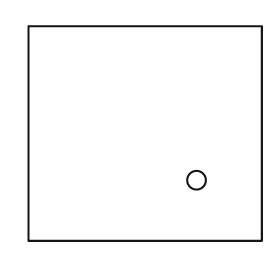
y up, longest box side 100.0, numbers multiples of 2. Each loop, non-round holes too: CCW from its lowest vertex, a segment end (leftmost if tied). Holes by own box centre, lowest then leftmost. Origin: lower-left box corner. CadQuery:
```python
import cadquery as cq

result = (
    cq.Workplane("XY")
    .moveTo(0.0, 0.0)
    .lineTo(100.0, 0.0)
    .lineTo(100.0, 92.0)
    .lineTo(0.0, 92.0)
    .close()
    .moveTo(72.0, 26.0)
    .circle(4.0)
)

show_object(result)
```